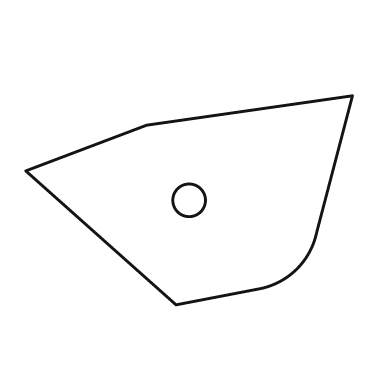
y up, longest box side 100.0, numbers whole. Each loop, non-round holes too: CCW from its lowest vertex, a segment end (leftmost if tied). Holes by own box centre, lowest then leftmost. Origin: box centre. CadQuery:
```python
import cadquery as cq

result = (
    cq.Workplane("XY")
    .moveTo(-4.0, -32.0)
    .lineTo(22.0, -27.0)
    .threePointArc((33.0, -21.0), (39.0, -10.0))
    .lineTo(50.0, 32.0)
    .lineTo(-13.0, 23.0)
    .lineTo(-50.0, 9.0)
    .close()
    .moveTo(0.0, 0.0)
    .circle(5.0)
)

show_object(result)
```